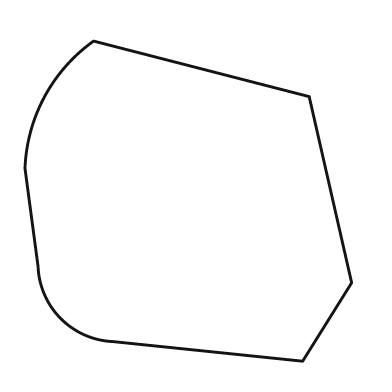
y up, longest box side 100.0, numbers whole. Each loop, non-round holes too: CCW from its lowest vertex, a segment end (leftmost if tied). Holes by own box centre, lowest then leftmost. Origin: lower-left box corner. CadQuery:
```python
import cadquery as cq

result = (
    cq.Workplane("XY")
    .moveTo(85.0, 0.0)
    .lineTo(100.0, 24.0)
    .lineTo(87.0, 81.0)
    .lineTo(21.0, 98.0)
    .threePointArc((6.0, 81.0), (0.0, 59.0))
    .lineTo(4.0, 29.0)
    .threePointArc((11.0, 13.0), (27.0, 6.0))
    .close()
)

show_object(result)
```